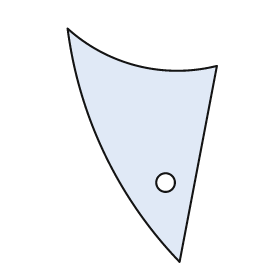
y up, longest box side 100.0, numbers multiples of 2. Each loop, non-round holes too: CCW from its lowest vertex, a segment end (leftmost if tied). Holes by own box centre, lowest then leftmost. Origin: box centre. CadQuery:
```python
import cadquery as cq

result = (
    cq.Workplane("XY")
    .moveTo(16.0, -50.0)
    .lineTo(32.0, 34.0)
    .threePointArc((-2.0, 34.0), (-32.0, 50.0))
    .threePointArc((-16.0, -4.0), (16.0, -50.0))
    .close()
    .moveTo(10.0, -16.0)
    .circle(4.0)
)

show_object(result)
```